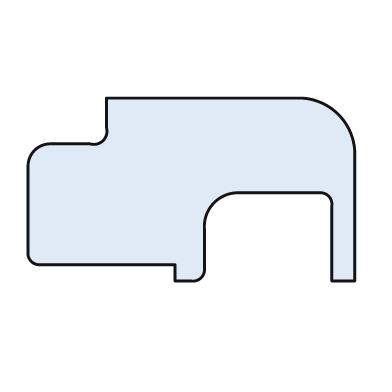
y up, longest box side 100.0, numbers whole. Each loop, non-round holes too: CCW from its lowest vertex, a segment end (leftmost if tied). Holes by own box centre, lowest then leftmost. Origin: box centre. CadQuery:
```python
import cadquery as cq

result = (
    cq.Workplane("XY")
    .moveTo(-5.0, -28.0)
    .lineTo(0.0, -28.0)
    .threePointArc((3.0, -27.0), (4.0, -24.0))
    .lineTo(4.0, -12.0)
    .threePointArc((7.0, -4.0), (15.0, -1.0))
    .lineTo(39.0, -1.0)
    .threePointArc((42.0, -2.0), (43.0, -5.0))
    .lineTo(43.0, -28.0)
    .lineTo(50.0, -28.0)
    .lineTo(50.0, 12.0)
    .threePointArc((45.0, 23.0), (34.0, 28.0))
    .lineTo(-26.0, 28.0)
    .lineTo(-26.0, 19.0)
    .threePointArc((-27.0, 15.0), (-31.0, 14.0))
    .lineTo(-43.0, 14.0)
    .threePointArc((-48.0, 12.0), (-50.0, 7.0))
    .lineTo(-50.0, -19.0)
    .threePointArc((-49.0, -22.0), (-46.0, -23.0))
    .lineTo(-5.0, -23.0)
    .close()
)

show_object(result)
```